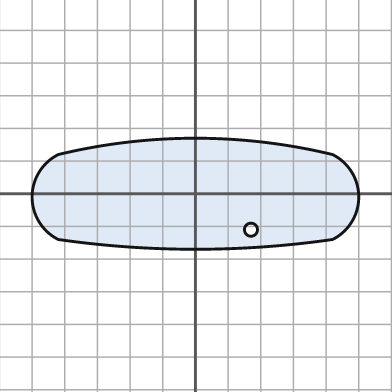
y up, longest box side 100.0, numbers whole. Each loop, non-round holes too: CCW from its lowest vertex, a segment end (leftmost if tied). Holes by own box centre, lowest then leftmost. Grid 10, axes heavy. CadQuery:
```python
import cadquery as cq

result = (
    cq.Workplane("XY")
    .moveTo(-42.0, -14.0)
    .threePointArc((0.0, -17.0), (42.0, -14.0))
    .threePointArc((50.0, -1.0), (42.0, 12.0))
    .threePointArc((0.0, 17.0), (-42.0, 12.0))
    .threePointArc((-50.0, -1.0), (-42.0, -14.0))
    .close()
    .moveTo(17.0, -11.0)
    .circle(2.0)
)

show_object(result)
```